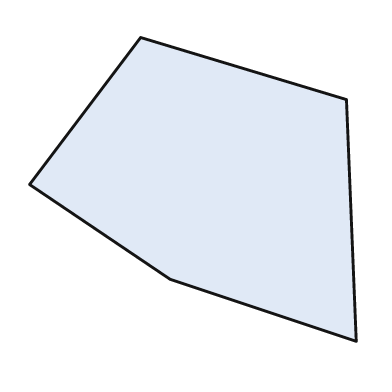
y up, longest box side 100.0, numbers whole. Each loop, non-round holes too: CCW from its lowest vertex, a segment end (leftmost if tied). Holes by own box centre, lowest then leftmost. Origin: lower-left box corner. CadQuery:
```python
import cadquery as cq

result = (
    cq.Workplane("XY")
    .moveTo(100.0, 0.0)
    .lineTo(97.0, 74.0)
    .lineTo(34.0, 93.0)
    .lineTo(0.0, 48.0)
    .lineTo(43.0, 19.0)
    .close()
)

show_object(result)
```